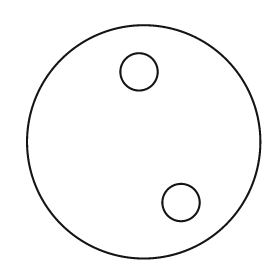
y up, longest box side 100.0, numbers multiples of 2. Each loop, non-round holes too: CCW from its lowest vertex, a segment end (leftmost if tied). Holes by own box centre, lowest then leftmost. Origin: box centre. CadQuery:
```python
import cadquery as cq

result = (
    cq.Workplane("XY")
    .moveTo(0.0, 0.0)
    .circle(50.0)
    .moveTo(16.0, -26.0)
    .circle(8.0)
    .moveTo(-2.0, 30.0)
    .circle(8.0)
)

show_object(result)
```